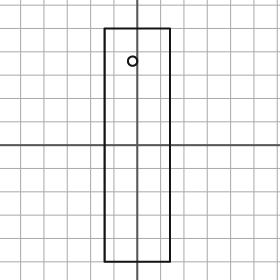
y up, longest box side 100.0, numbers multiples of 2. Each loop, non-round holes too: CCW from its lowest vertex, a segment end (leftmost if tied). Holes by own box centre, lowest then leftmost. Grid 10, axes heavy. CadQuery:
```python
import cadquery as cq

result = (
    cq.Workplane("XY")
    .moveTo(-14.0, -50.0)
    .lineTo(14.0, -50.0)
    .lineTo(14.0, 50.0)
    .lineTo(-14.0, 50.0)
    .close()
    .moveTo(-2.0, 36.0)
    .circle(2.0)
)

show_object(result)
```